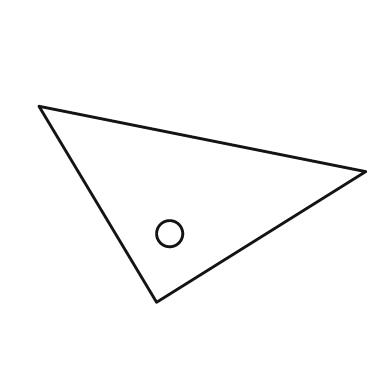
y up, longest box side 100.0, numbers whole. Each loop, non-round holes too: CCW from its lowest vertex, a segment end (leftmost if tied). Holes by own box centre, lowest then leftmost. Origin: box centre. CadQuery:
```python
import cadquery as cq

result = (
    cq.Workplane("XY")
    .moveTo(-14.0, -30.0)
    .lineTo(50.0, 10.0)
    .lineTo(-50.0, 30.0)
    .close()
    .moveTo(-10.0, -9.0)
    .circle(4.0)
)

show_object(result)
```